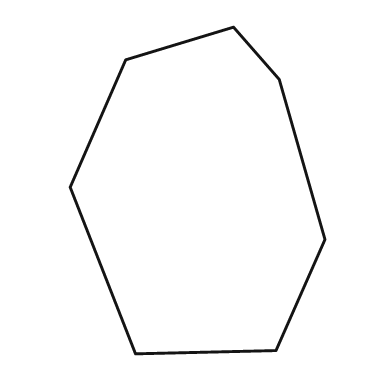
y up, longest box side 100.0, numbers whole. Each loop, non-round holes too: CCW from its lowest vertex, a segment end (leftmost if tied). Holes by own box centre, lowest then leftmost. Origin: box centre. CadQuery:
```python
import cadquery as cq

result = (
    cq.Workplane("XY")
    .moveTo(-19.0, -50.0)
    .lineTo(24.0, -49.0)
    .lineTo(39.0, -15.0)
    .lineTo(25.0, 34.0)
    .lineTo(11.0, 50.0)
    .lineTo(-22.0, 40.0)
    .lineTo(-39.0, 1.0)
    .close()
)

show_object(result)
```